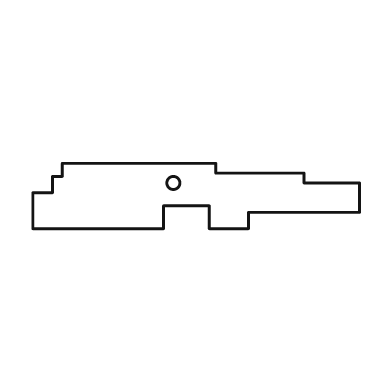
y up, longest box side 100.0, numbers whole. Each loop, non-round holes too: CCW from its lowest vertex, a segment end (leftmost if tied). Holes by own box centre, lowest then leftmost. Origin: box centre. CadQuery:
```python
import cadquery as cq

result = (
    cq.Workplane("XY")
    .moveTo(-50.0, -10.0)
    .lineTo(-10.0, -10.0)
    .lineTo(-10.0, -3.0)
    .lineTo(4.0, -3.0)
    .lineTo(4.0, -10.0)
    .lineTo(16.0, -10.0)
    .lineTo(16.0, -5.0)
    .lineTo(50.0, -5.0)
    .lineTo(50.0, 4.0)
    .lineTo(33.0, 4.0)
    .lineTo(33.0, 7.0)
    .lineTo(6.0, 7.0)
    .lineTo(6.0, 10.0)
    .lineTo(-41.0, 10.0)
    .lineTo(-41.0, 6.0)
    .lineTo(-44.0, 6.0)
    .lineTo(-44.0, 1.0)
    .lineTo(-50.0, 1.0)
    .close()
    .moveTo(-7.0, 4.0)
    .circle(2.0)
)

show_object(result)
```